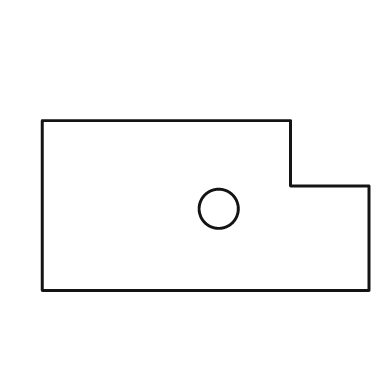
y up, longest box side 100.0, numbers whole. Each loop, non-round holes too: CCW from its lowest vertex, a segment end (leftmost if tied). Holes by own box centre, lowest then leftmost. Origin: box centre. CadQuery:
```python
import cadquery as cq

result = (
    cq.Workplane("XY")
    .moveTo(-50.0, -26.0)
    .lineTo(50.0, -26.0)
    .lineTo(50.0, 6.0)
    .lineTo(26.0, 6.0)
    .lineTo(26.0, 26.0)
    .lineTo(-50.0, 26.0)
    .close()
    .moveTo(4.0, -1.0)
    .circle(6.0)
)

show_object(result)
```